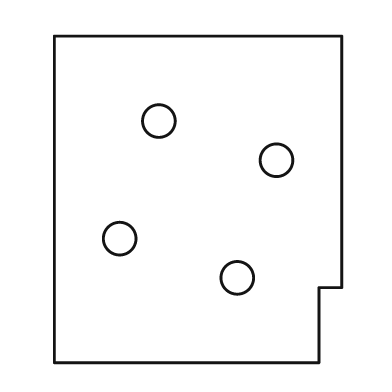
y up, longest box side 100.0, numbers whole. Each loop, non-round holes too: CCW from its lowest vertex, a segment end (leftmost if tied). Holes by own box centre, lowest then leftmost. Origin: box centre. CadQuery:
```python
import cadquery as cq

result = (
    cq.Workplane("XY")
    .moveTo(-44.0, -50.0)
    .lineTo(37.0, -50.0)
    .lineTo(37.0, -27.0)
    .lineTo(44.0, -27.0)
    .lineTo(44.0, 50.0)
    .lineTo(-44.0, 50.0)
    .close()
    .moveTo(12.0, -24.0)
    .circle(5.0)
    .moveTo(-24.0, -12.0)
    .circle(5.0)
    .moveTo(24.0, 12.0)
    .circle(5.0)
    .moveTo(-12.0, 24.0)
    .circle(5.0)
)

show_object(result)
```